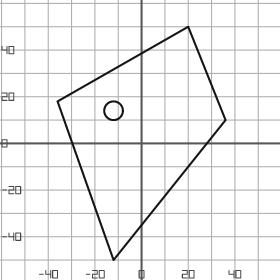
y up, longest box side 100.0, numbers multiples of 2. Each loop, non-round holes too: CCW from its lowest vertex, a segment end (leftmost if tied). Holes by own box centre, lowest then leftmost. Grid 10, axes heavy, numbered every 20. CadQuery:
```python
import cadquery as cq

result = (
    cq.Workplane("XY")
    .moveTo(-12.0, -50.0)
    .lineTo(36.0, 10.0)
    .lineTo(20.0, 50.0)
    .lineTo(-36.0, 18.0)
    .close()
    .moveTo(-12.0, 14.0)
    .circle(4.0)
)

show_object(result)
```